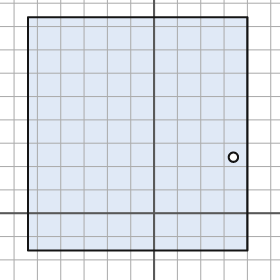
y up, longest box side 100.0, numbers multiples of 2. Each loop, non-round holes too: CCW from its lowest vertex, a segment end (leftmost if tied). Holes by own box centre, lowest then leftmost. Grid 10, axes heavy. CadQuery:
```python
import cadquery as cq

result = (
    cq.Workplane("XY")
    .moveTo(-54.0, -16.0)
    .lineTo(40.0, -16.0)
    .lineTo(40.0, 84.0)
    .lineTo(-54.0, 84.0)
    .close()
    .moveTo(34.0, 24.0)
    .circle(2.0)
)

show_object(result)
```